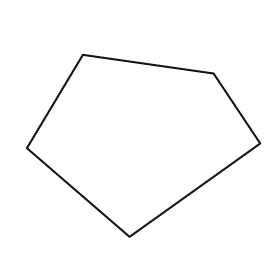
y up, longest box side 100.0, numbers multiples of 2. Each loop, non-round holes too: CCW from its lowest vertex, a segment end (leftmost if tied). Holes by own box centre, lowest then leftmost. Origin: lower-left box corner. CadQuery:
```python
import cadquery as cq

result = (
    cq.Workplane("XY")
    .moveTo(44.0, 0.0)
    .lineTo(100.0, 40.0)
    .lineTo(80.0, 70.0)
    .lineTo(24.0, 78.0)
    .lineTo(0.0, 38.0)
    .close()
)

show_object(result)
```